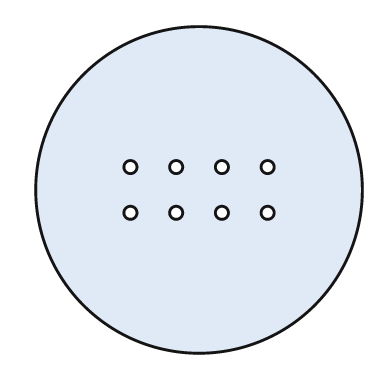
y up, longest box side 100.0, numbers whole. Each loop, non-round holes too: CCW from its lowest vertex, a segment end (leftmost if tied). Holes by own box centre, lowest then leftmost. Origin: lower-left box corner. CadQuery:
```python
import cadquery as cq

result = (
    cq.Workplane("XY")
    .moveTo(50.0, 50.0)
    .circle(50.0)
    .moveTo(29.0, 43.0)
    .circle(2.0)
    .moveTo(43.0, 43.0)
    .circle(2.0)
    .moveTo(57.0, 43.0)
    .circle(2.0)
    .moveTo(71.0, 43.0)
    .circle(2.0)
    .moveTo(29.0, 57.0)
    .circle(2.0)
    .moveTo(43.0, 57.0)
    .circle(2.0)
    .moveTo(57.0, 57.0)
    .circle(2.0)
    .moveTo(71.0, 57.0)
    .circle(2.0)
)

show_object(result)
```